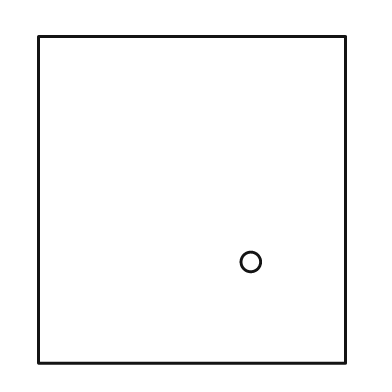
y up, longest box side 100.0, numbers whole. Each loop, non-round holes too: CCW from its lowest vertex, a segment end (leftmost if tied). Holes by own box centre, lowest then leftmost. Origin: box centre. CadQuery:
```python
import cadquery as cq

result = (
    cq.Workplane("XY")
    .moveTo(-47.0, -50.0)
    .lineTo(47.0, -50.0)
    .lineTo(47.0, 50.0)
    .lineTo(-47.0, 50.0)
    .close()
    .moveTo(18.0, -19.0)
    .circle(3.0)
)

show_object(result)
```